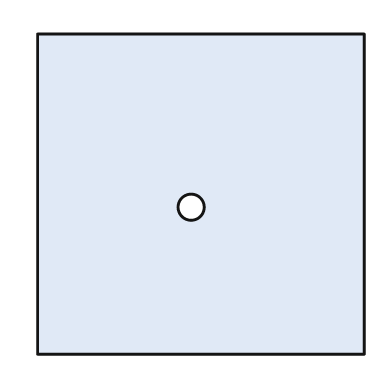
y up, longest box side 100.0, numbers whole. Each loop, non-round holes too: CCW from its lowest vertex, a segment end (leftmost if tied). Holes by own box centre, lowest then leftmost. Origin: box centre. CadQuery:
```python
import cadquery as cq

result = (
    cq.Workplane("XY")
    .moveTo(-50.0, -49.0)
    .lineTo(50.0, -49.0)
    .lineTo(50.0, 49.0)
    .lineTo(-50.0, 49.0)
    .close()
    .moveTo(-3.0, -4.0)
    .circle(4.0)
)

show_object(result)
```